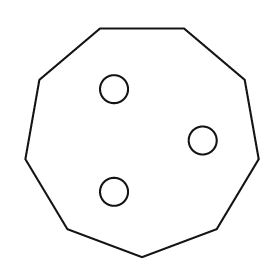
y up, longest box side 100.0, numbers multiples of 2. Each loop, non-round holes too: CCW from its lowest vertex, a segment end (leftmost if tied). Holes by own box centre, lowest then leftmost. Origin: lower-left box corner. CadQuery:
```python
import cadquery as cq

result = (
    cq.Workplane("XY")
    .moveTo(50.0, 0.0)
    .lineTo(82.0, 12.0)
    .lineTo(100.0, 42.0)
    .lineTo(94.0, 76.0)
    .lineTo(68.0, 98.0)
    .lineTo(32.0, 98.0)
    .lineTo(6.0, 76.0)
    .lineTo(0.0, 42.0)
    .lineTo(18.0, 12.0)
    .close()
    .moveTo(38.0, 28.0)
    .circle(6.0)
    .moveTo(76.0, 50.0)
    .circle(6.0)
    .moveTo(38.0, 72.0)
    .circle(6.0)
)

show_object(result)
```